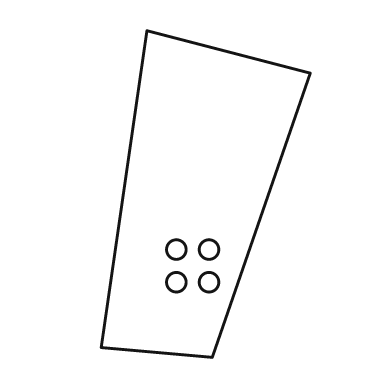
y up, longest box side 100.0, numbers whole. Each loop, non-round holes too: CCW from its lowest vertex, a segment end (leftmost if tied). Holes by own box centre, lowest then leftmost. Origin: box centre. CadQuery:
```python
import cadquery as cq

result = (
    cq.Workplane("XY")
    .moveTo(2.0, -50.0)
    .lineTo(32.0, 37.0)
    .lineTo(-18.0, 50.0)
    .lineTo(-32.0, -47.0)
    .close()
    .moveTo(-9.0, -27.0)
    .circle(3.0)
    .moveTo(1.0, -27.0)
    .circle(3.0)
    .moveTo(-9.0, -17.0)
    .circle(3.0)
    .moveTo(1.0, -17.0)
    .circle(3.0)
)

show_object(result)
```